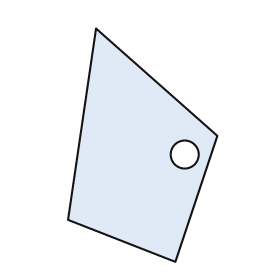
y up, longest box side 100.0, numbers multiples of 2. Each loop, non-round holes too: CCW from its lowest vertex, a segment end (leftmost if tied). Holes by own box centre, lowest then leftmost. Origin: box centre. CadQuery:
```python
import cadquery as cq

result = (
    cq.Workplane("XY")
    .moveTo(14.0, -50.0)
    .lineTo(32.0, 4.0)
    .lineTo(-20.0, 50.0)
    .lineTo(-32.0, -32.0)
    .close()
    .moveTo(18.0, -4.0)
    .circle(6.0)
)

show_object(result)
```